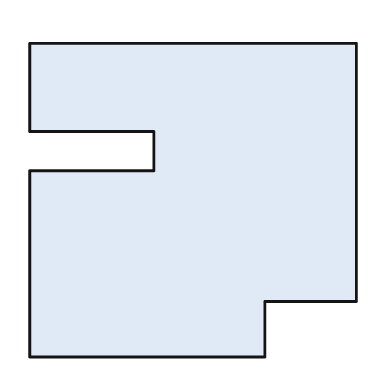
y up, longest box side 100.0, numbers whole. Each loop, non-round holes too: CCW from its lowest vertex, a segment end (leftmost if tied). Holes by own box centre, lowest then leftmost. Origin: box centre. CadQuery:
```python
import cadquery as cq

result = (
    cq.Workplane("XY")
    .moveTo(-50.0, -48.0)
    .lineTo(22.0, -48.0)
    .lineTo(22.0, -31.0)
    .lineTo(50.0, -31.0)
    .lineTo(50.0, 48.0)
    .lineTo(-50.0, 48.0)
    .lineTo(-50.0, 21.0)
    .lineTo(-12.0, 21.0)
    .lineTo(-12.0, 9.0)
    .lineTo(-50.0, 9.0)
    .close()
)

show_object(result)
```